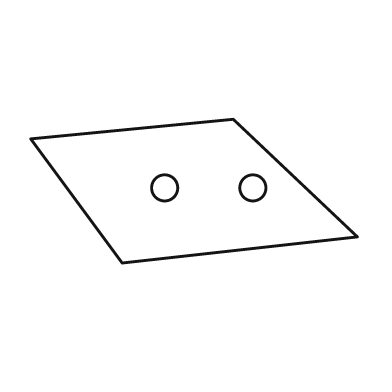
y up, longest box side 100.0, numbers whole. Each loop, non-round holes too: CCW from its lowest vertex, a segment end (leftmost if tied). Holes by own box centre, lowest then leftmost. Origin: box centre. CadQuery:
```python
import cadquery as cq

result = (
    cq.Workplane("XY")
    .moveTo(-22.0, -22.0)
    .lineTo(50.0, -14.0)
    .lineTo(12.0, 22.0)
    .lineTo(-50.0, 16.0)
    .close()
    .moveTo(-9.0, 1.0)
    .circle(4.0)
    .moveTo(18.0, 1.0)
    .circle(4.0)
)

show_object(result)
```